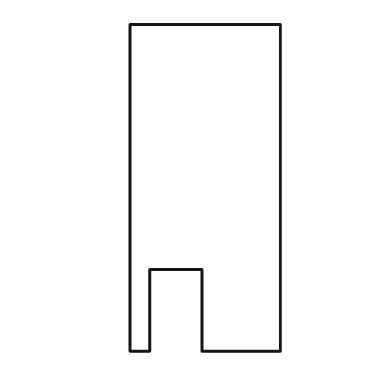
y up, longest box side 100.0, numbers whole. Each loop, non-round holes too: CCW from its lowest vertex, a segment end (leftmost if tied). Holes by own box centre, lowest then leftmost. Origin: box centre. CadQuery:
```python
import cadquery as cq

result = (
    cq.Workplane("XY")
    .moveTo(-23.0, -50.0)
    .lineTo(-17.0, -50.0)
    .lineTo(-17.0, -25.0)
    .lineTo(-1.0, -25.0)
    .lineTo(-1.0, -50.0)
    .lineTo(23.0, -50.0)
    .lineTo(23.0, 50.0)
    .lineTo(-23.0, 50.0)
    .close()
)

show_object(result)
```